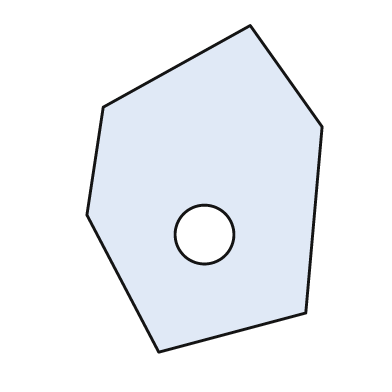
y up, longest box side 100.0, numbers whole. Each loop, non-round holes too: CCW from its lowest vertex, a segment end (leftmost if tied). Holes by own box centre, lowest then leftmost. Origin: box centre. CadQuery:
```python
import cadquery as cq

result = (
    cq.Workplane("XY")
    .moveTo(-14.0, -50.0)
    .lineTo(31.0, -38.0)
    .lineTo(36.0, 19.0)
    .lineTo(14.0, 50.0)
    .lineTo(-31.0, 25.0)
    .lineTo(-36.0, -8.0)
    .close()
    .moveTo(0.0, -14.0)
    .circle(9.0)
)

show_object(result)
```